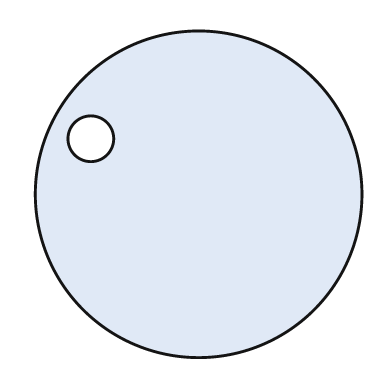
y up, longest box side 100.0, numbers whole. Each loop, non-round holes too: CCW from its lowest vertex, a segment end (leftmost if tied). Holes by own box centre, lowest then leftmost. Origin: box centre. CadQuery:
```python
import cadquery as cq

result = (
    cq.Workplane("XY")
    .moveTo(0.0, 0.0)
    .circle(50.0)
    .moveTo(-33.0, 17.0)
    .circle(7.0)
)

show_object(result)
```